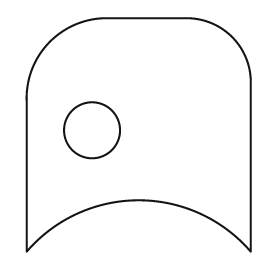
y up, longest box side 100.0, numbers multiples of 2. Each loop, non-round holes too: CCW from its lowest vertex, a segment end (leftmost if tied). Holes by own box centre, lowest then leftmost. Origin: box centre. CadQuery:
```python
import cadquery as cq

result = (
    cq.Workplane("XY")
    .moveTo(-48.0, -50.0)
    .threePointArc((0.0, -28.0), (48.0, -50.0))
    .lineTo(48.0, 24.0)
    .threePointArc((40.0, 42.0), (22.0, 50.0))
    .lineTo(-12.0, 50.0)
    .threePointArc((-38.0, 40.0), (-48.0, 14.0))
    .close()
    .moveTo(-20.0, 2.0)
    .circle(12.0)
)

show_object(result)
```